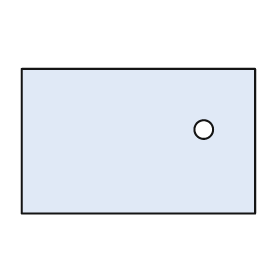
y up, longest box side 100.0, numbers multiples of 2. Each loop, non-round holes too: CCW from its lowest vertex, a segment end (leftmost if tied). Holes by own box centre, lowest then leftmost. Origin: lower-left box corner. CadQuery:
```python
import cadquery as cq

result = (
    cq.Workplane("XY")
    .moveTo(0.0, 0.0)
    .lineTo(100.0, 0.0)
    .lineTo(100.0, 62.0)
    .lineTo(0.0, 62.0)
    .close()
    .moveTo(78.0, 36.0)
    .circle(4.0)
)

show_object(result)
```